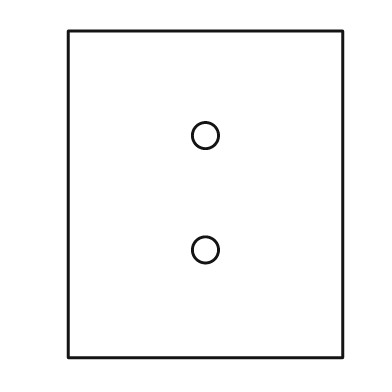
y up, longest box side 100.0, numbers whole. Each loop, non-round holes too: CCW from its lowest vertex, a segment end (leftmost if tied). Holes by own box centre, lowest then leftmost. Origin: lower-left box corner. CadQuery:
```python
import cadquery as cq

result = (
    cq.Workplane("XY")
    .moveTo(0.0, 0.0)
    .lineTo(84.0, 0.0)
    .lineTo(84.0, 100.0)
    .lineTo(0.0, 100.0)
    .close()
    .moveTo(42.0, 33.0)
    .circle(4.0)
    .moveTo(42.0, 68.0)
    .circle(4.0)
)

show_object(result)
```